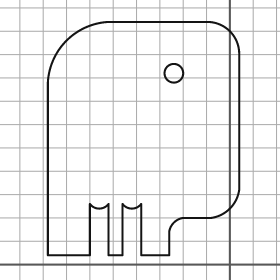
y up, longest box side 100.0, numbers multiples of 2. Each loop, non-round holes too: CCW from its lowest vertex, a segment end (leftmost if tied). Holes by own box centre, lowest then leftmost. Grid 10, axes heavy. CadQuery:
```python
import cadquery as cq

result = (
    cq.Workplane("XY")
    .moveTo(-78.0, 4.0)
    .lineTo(-60.0, 4.0)
    .lineTo(-60.0, 26.0)
    .threePointArc((-56.0, 24.0), (-52.0, 26.0))
    .lineTo(-52.0, 4.0)
    .lineTo(-46.0, 4.0)
    .lineTo(-46.0, 26.0)
    .threePointArc((-42.0, 24.0), (-38.0, 26.0))
    .lineTo(-38.0, 4.0)
    .lineTo(-26.0, 4.0)
    .lineTo(-26.0, 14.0)
    .threePointArc((-24.0, 18.0), (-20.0, 20.0))
    .lineTo(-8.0, 20.0)
    .threePointArc((0.0, 24.0), (4.0, 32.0))
    .lineTo(4.0, 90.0)
    .threePointArc((0.0, 100.0), (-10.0, 104.0))
    .lineTo(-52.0, 104.0)
    .threePointArc((-70.0, 96.0), (-78.0, 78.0))
    .close()
    .moveTo(-24.0, 82.0)
    .circle(4.0)
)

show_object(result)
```